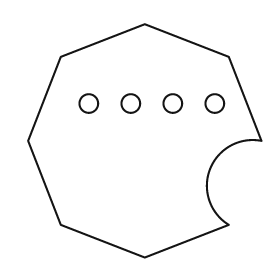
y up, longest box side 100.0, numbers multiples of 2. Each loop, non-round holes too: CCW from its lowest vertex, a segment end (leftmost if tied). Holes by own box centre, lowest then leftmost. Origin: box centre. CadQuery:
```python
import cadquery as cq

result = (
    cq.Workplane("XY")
    .moveTo(0.0, -50.0)
    .lineTo(36.0, -36.0)
    .threePointArc((28.0, -12.0), (50.0, 0.0))
    .lineTo(36.0, 36.0)
    .lineTo(0.0, 50.0)
    .lineTo(-36.0, 36.0)
    .lineTo(-50.0, 0.0)
    .lineTo(-36.0, -36.0)
    .close()
    .moveTo(-24.0, 16.0)
    .circle(4.0)
    .moveTo(-6.0, 16.0)
    .circle(4.0)
    .moveTo(12.0, 16.0)
    .circle(4.0)
    .moveTo(30.0, 16.0)
    .circle(4.0)
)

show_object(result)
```